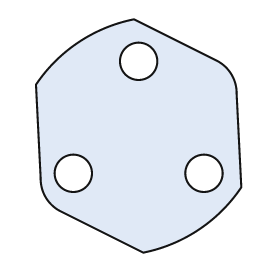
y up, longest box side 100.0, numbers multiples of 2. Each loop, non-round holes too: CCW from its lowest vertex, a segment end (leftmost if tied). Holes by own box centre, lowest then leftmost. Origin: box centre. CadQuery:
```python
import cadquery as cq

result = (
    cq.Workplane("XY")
    .moveTo(2.0, -50.0)
    .threePointArc((26.0, -40.0), (44.0, -22.0))
    .lineTo(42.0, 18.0)
    .threePointArc((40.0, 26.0), (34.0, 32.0))
    .lineTo(-2.0, 50.0)
    .threePointArc((-26.0, 40.0), (-44.0, 22.0))
    .lineTo(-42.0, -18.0)
    .threePointArc((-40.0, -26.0), (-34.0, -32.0))
    .close()
    .moveTo(-28.0, -16.0)
    .circle(8.0)
    .moveTo(28.0, -16.0)
    .circle(8.0)
    .moveTo(0.0, 32.0)
    .circle(8.0)
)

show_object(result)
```